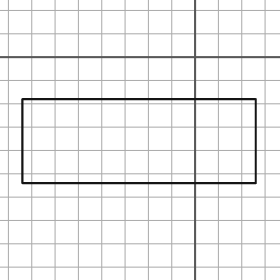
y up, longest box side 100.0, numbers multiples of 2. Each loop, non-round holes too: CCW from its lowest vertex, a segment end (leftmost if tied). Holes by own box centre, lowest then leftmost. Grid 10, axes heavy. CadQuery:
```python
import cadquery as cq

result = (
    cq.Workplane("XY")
    .moveTo(-74.0, -54.0)
    .lineTo(26.0, -54.0)
    .lineTo(26.0, -18.0)
    .lineTo(-74.0, -18.0)
    .close()
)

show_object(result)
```